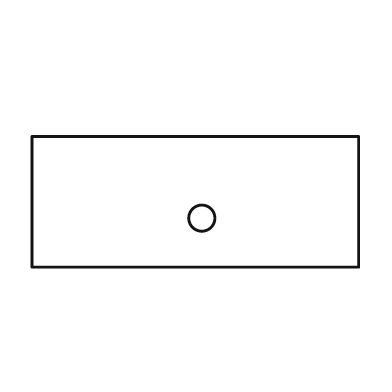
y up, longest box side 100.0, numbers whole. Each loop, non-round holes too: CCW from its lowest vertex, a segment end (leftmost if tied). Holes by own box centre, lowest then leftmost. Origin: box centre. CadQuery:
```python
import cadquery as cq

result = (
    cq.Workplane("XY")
    .moveTo(-50.0, -20.0)
    .lineTo(50.0, -20.0)
    .lineTo(50.0, 20.0)
    .lineTo(-50.0, 20.0)
    .close()
    .moveTo(2.0, -5.0)
    .circle(4.0)
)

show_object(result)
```